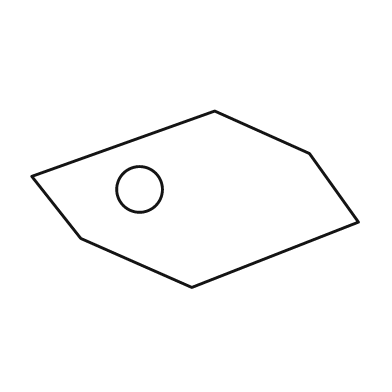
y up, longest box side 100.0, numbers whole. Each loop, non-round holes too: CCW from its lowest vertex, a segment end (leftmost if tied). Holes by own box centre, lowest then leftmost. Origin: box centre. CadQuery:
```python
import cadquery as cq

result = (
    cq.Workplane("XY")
    .moveTo(-1.0, -27.0)
    .lineTo(50.0, -7.0)
    .lineTo(35.0, 14.0)
    .lineTo(6.0, 27.0)
    .lineTo(-50.0, 7.0)
    .lineTo(-35.0, -12.0)
    .close()
    .moveTo(-17.0, 3.0)
    .circle(7.0)
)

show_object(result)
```